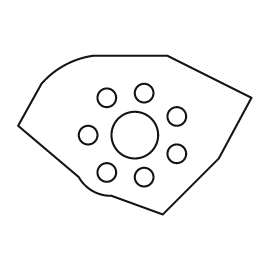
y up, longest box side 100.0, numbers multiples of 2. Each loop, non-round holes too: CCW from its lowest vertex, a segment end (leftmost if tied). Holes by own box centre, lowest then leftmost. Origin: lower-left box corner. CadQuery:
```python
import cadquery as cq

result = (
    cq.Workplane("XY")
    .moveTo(62.0, 0.0)
    .lineTo(86.0, 24.0)
    .lineTo(100.0, 50.0)
    .lineTo(64.0, 68.0)
    .lineTo(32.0, 68.0)
    .threePointArc((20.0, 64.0), (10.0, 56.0))
    .lineTo(0.0, 38.0)
    .lineTo(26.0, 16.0)
    .threePointArc((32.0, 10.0), (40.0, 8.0))
    .close()
    .moveTo(54.0, 16.0)
    .circle(4.0)
    .moveTo(38.0, 18.0)
    .circle(4.0)
    .moveTo(68.0, 26.0)
    .circle(4.0)
    .moveTo(30.0, 34.0)
    .circle(4.0)
    .moveTo(50.0, 34.0)
    .circle(10.0)
    .moveTo(68.0, 42.0)
    .circle(4.0)
    .moveTo(38.0, 50.0)
    .circle(4.0)
    .moveTo(54.0, 52.0)
    .circle(4.0)
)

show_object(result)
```